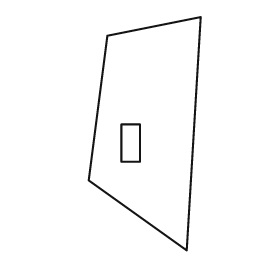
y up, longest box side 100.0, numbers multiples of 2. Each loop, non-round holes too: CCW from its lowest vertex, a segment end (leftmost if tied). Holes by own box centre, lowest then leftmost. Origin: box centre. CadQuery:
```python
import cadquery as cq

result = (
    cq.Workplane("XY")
    .moveTo(18.0, -50.0)
    .lineTo(24.0, 50.0)
    .lineTo(-16.0, 42.0)
    .lineTo(-24.0, -20.0)
    .close()
    .moveTo(-10.0, -12.0)
    .lineTo(-2.0, -12.0)
    .lineTo(-2.0, 4.0)
    .lineTo(-10.0, 4.0)
    .close()
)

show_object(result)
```